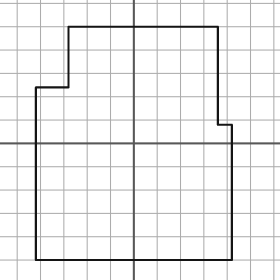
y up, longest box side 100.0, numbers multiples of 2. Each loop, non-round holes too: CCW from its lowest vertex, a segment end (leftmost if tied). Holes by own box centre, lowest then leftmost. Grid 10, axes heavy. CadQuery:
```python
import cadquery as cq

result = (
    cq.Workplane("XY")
    .moveTo(-42.0, -50.0)
    .lineTo(42.0, -50.0)
    .lineTo(42.0, 8.0)
    .lineTo(36.0, 8.0)
    .lineTo(36.0, 50.0)
    .lineTo(-28.0, 50.0)
    .lineTo(-28.0, 24.0)
    .lineTo(-42.0, 24.0)
    .close()
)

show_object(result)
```